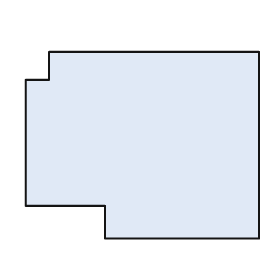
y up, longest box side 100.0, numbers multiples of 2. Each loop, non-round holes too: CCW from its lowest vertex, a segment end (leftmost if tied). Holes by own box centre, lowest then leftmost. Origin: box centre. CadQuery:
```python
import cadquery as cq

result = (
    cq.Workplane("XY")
    .moveTo(-16.0, -40.0)
    .lineTo(50.0, -40.0)
    .lineTo(50.0, 40.0)
    .lineTo(-40.0, 40.0)
    .lineTo(-40.0, 28.0)
    .lineTo(-50.0, 28.0)
    .lineTo(-50.0, -26.0)
    .lineTo(-16.0, -26.0)
    .close()
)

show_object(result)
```